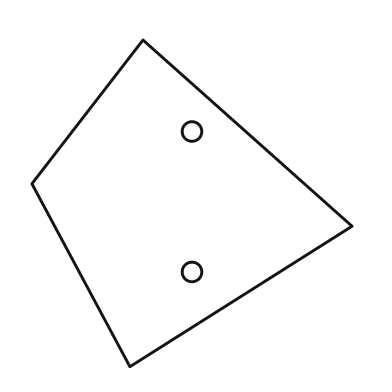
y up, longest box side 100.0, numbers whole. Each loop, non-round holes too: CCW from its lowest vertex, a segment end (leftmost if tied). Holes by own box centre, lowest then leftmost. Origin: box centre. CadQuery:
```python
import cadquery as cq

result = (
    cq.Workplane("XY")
    .moveTo(-19.0, -50.0)
    .lineTo(49.0, -7.0)
    .lineTo(-15.0, 50.0)
    .lineTo(-49.0, 6.0)
    .close()
    .moveTo(0.0, -21.0)
    .circle(3.0)
    .moveTo(0.0, 22.0)
    .circle(3.0)
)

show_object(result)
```